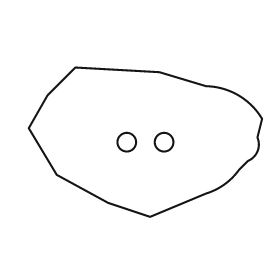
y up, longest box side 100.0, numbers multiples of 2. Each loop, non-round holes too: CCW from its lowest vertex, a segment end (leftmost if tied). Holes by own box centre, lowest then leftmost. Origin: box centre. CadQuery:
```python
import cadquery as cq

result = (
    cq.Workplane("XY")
    .moveTo(2.0, -32.0)
    .lineTo(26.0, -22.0)
    .threePointArc((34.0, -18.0), (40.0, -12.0))
    .lineTo(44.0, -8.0)
    .threePointArc((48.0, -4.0), (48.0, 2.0))
    .lineTo(50.0, 10.0)
    .threePointArc((40.0, 20.0), (26.0, 24.0))
    .lineTo(6.0, 30.0)
    .lineTo(-30.0, 32.0)
    .lineTo(-42.0, 20.0)
    .lineTo(-50.0, 6.0)
    .lineTo(-38.0, -14.0)
    .lineTo(-16.0, -26.0)
    .close()
    .moveTo(-8.0, 0.0)
    .circle(4.0)
    .moveTo(8.0, 0.0)
    .circle(4.0)
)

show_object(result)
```